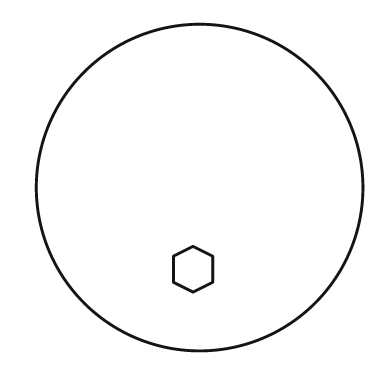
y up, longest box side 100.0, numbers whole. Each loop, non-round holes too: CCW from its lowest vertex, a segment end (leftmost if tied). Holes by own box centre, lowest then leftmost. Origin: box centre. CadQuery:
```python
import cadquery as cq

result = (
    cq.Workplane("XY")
    .moveTo(0.0, 0.0)
    .circle(50.0)
    .moveTo(-2.0, -32.0)
    .lineTo(4.0, -29.0)
    .lineTo(4.0, -21.0)
    .lineTo(-2.0, -18.0)
    .lineTo(-8.0, -21.0)
    .lineTo(-8.0, -29.0)
    .close()
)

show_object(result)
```